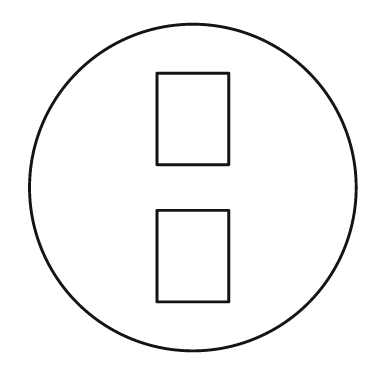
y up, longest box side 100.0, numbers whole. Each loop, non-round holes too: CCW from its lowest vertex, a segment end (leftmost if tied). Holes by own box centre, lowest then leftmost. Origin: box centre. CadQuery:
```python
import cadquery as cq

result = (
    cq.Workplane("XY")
    .moveTo(0.0, 0.0)
    .circle(50.0)
    .moveTo(-11.0, -35.0)
    .lineTo(11.0, -35.0)
    .lineTo(11.0, -7.0)
    .lineTo(-11.0, -7.0)
    .close()
    .moveTo(-11.0, 7.0)
    .lineTo(11.0, 7.0)
    .lineTo(11.0, 35.0)
    .lineTo(-11.0, 35.0)
    .close()
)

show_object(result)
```